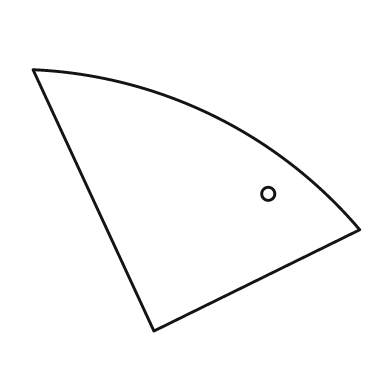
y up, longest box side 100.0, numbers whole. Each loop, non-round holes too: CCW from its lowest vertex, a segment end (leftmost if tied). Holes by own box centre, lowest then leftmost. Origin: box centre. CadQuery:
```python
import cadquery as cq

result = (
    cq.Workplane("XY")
    .moveTo(-13.0, -40.0)
    .lineTo(50.0, -9.0)
    .threePointArc((5.0, 26.0), (-50.0, 40.0))
    .close()
    .moveTo(22.0, 2.0)
    .circle(2.0)
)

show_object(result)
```